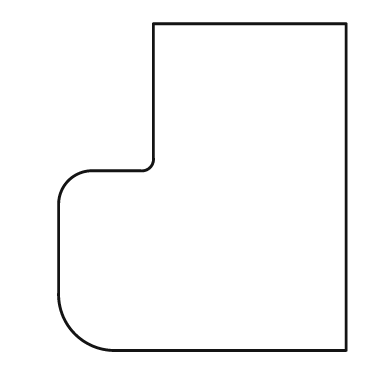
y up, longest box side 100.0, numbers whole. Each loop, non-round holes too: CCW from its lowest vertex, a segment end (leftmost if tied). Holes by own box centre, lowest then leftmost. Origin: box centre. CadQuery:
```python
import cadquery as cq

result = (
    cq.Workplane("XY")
    .moveTo(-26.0, -50.0)
    .lineTo(44.0, -50.0)
    .lineTo(44.0, 50.0)
    .lineTo(-15.0, 50.0)
    .lineTo(-15.0, 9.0)
    .threePointArc((-16.0, 6.0), (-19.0, 5.0))
    .lineTo(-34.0, 5.0)
    .threePointArc((-41.0, 2.0), (-44.0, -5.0))
    .lineTo(-44.0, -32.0)
    .threePointArc((-39.0, -45.0), (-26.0, -50.0))
    .close()
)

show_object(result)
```